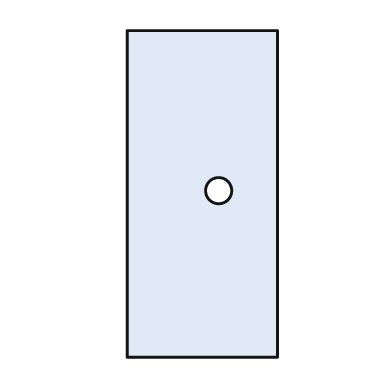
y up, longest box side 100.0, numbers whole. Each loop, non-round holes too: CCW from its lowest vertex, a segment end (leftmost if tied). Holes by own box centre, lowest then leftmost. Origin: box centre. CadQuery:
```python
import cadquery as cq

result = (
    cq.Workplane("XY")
    .moveTo(-23.0, -50.0)
    .lineTo(23.0, -50.0)
    .lineTo(23.0, 50.0)
    .lineTo(-23.0, 50.0)
    .close()
    .moveTo(5.0, 1.0)
    .circle(4.0)
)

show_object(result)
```